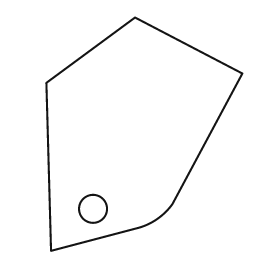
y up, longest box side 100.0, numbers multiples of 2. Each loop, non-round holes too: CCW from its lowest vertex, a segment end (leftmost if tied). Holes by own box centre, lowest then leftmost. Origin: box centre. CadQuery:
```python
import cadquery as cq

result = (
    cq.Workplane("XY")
    .moveTo(-40.0, -50.0)
    .lineTo(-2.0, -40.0)
    .threePointArc((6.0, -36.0), (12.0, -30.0))
    .lineTo(42.0, 26.0)
    .lineTo(-4.0, 50.0)
    .lineTo(-42.0, 22.0)
    .close()
    .moveTo(-22.0, -32.0)
    .circle(6.0)
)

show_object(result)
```